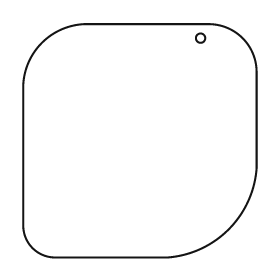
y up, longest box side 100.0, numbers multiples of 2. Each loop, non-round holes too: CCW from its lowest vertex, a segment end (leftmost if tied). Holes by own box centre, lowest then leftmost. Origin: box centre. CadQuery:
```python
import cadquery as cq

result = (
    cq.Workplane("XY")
    .moveTo(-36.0, -50.0)
    .lineTo(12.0, -50.0)
    .threePointArc((38.0, -38.0), (50.0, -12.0))
    .lineTo(50.0, 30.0)
    .threePointArc((44.0, 44.0), (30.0, 50.0))
    .lineTo(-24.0, 50.0)
    .threePointArc((-42.0, 42.0), (-50.0, 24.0))
    .lineTo(-50.0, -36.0)
    .threePointArc((-46.0, -46.0), (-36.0, -50.0))
    .close()
    .moveTo(26.0, 44.0)
    .circle(2.0)
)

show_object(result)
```